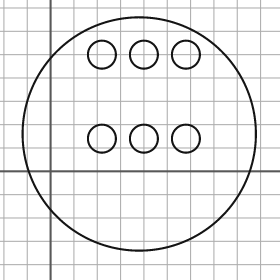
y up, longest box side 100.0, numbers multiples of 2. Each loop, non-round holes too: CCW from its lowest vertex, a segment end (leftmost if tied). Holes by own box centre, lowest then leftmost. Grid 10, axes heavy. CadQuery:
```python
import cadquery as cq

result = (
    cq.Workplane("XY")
    .moveTo(38.0, 16.0)
    .circle(50.0)
    .moveTo(22.0, 14.0)
    .circle(6.0)
    .moveTo(40.0, 14.0)
    .circle(6.0)
    .moveTo(58.0, 14.0)
    .circle(6.0)
    .moveTo(22.0, 50.0)
    .circle(6.0)
    .moveTo(40.0, 50.0)
    .circle(6.0)
    .moveTo(58.0, 50.0)
    .circle(6.0)
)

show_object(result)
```